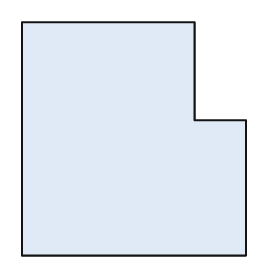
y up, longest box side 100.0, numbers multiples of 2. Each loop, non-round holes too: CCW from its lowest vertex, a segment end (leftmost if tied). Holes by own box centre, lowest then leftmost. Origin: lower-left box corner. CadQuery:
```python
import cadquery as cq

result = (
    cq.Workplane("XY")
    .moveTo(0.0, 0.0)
    .lineTo(96.0, 0.0)
    .lineTo(96.0, 58.0)
    .lineTo(74.0, 58.0)
    .lineTo(74.0, 100.0)
    .lineTo(0.0, 100.0)
    .close()
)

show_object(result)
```